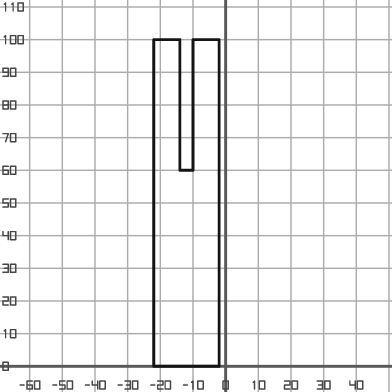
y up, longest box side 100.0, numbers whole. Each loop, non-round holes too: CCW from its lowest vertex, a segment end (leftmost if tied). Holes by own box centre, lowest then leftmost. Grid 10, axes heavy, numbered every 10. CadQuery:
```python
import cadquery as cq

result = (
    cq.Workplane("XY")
    .moveTo(-22.0, 0.0)
    .lineTo(-2.0, 0.0)
    .lineTo(-2.0, 100.0)
    .lineTo(-10.0, 100.0)
    .lineTo(-10.0, 60.0)
    .lineTo(-14.0, 60.0)
    .lineTo(-14.0, 100.0)
    .lineTo(-22.0, 100.0)
    .close()
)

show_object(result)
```